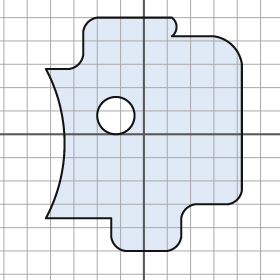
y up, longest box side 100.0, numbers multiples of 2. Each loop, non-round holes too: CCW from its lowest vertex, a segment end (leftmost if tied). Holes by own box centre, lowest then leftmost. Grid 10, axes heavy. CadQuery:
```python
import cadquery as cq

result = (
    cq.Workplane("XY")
    .moveTo(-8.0, -50.0)
    .lineTo(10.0, -50.0)
    .threePointArc((14.0, -48.0), (16.0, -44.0))
    .lineTo(16.0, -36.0)
    .threePointArc((18.0, -32.0), (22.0, -30.0))
    .lineTo(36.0, -30.0)
    .threePointArc((40.0, -28.0), (42.0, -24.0))
    .lineTo(42.0, 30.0)
    .threePointArc((38.0, 38.0), (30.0, 42.0))
    .lineTo(12.0, 42.0)
    .threePointArc((14.0, 46.0), (12.0, 50.0))
    .lineTo(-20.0, 50.0)
    .threePointArc((-24.0, 48.0), (-26.0, 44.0))
    .lineTo(-26.0, 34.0)
    .threePointArc((-28.0, 30.0), (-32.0, 28.0))
    .lineTo(-42.0, 28.0)
    .threePointArc((-34.0, -4.0), (-42.0, -36.0))
    .lineTo(-14.0, -36.0)
    .lineTo(-14.0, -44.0)
    .threePointArc((-12.0, -48.0), (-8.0, -50.0))
    .close()
    .moveTo(-12.0, 8.0)
    .circle(8.0)
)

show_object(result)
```